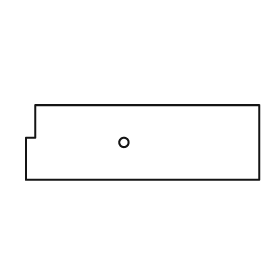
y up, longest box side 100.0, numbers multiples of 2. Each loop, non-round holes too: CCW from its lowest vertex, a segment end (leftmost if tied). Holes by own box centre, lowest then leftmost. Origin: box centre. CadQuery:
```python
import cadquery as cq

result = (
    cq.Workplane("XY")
    .moveTo(-50.0, -16.0)
    .lineTo(50.0, -16.0)
    .lineTo(50.0, 16.0)
    .lineTo(-46.0, 16.0)
    .lineTo(-46.0, 2.0)
    .lineTo(-50.0, 2.0)
    .close()
    .moveTo(-8.0, 0.0)
    .circle(2.0)
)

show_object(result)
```